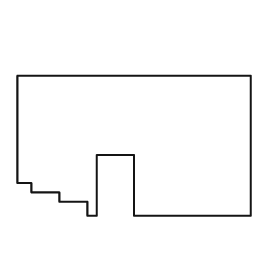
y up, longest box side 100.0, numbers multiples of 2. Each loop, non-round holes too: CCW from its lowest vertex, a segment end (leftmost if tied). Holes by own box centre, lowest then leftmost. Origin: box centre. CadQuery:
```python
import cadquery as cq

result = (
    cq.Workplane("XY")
    .moveTo(-20.0, -30.0)
    .lineTo(-16.0, -30.0)
    .lineTo(-16.0, -4.0)
    .lineTo(0.0, -4.0)
    .lineTo(0.0, -30.0)
    .lineTo(50.0, -30.0)
    .lineTo(50.0, 30.0)
    .lineTo(-50.0, 30.0)
    .lineTo(-50.0, -16.0)
    .lineTo(-44.0, -16.0)
    .lineTo(-44.0, -20.0)
    .lineTo(-32.0, -20.0)
    .lineTo(-32.0, -24.0)
    .lineTo(-20.0, -24.0)
    .close()
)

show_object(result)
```